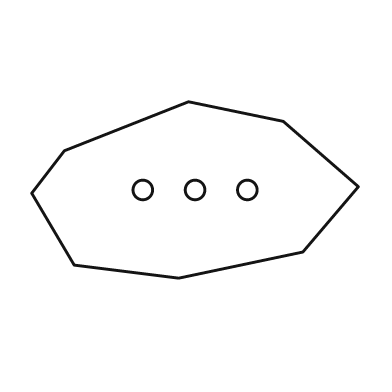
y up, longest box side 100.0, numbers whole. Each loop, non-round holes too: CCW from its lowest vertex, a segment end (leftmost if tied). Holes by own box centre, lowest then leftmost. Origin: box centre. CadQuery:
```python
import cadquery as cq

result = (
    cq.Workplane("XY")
    .moveTo(-5.0, -27.0)
    .lineTo(33.0, -19.0)
    .lineTo(50.0, 1.0)
    .lineTo(27.0, 21.0)
    .lineTo(-2.0, 27.0)
    .lineTo(-40.0, 12.0)
    .lineTo(-50.0, -1.0)
    .lineTo(-37.0, -23.0)
    .close()
    .moveTo(-16.0, 0.0)
    .circle(3.0)
    .moveTo(0.0, 0.0)
    .circle(3.0)
    .moveTo(16.0, 0.0)
    .circle(3.0)
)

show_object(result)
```